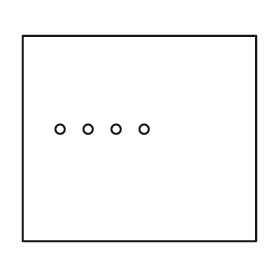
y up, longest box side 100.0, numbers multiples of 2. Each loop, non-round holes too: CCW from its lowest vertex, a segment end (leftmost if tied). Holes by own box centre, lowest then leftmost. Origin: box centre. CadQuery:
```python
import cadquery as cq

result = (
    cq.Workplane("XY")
    .moveTo(-50.0, -44.0)
    .lineTo(50.0, -44.0)
    .lineTo(50.0, 44.0)
    .lineTo(-50.0, 44.0)
    .close()
    .moveTo(-34.0, 4.0)
    .circle(2.0)
    .moveTo(-22.0, 4.0)
    .circle(2.0)
    .moveTo(-10.0, 4.0)
    .circle(2.0)
    .moveTo(2.0, 4.0)
    .circle(2.0)
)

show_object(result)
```